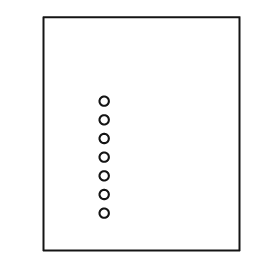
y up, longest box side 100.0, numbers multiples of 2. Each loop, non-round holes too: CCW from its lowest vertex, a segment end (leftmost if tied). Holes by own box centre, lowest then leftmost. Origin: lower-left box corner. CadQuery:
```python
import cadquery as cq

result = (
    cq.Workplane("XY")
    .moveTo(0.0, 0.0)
    .lineTo(84.0, 0.0)
    .lineTo(84.0, 100.0)
    .lineTo(0.0, 100.0)
    .close()
    .moveTo(26.0, 16.0)
    .circle(2.0)
    .moveTo(26.0, 24.0)
    .circle(2.0)
    .moveTo(26.0, 32.0)
    .circle(2.0)
    .moveTo(26.0, 40.0)
    .circle(2.0)
    .moveTo(26.0, 48.0)
    .circle(2.0)
    .moveTo(26.0, 56.0)
    .circle(2.0)
    .moveTo(26.0, 64.0)
    .circle(2.0)
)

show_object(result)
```